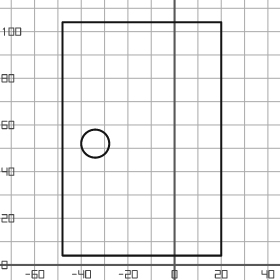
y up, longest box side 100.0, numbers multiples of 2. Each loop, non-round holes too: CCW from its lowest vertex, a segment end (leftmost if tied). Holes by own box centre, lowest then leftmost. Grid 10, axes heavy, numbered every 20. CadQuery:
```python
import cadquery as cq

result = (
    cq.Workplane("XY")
    .moveTo(-48.0, 4.0)
    .lineTo(20.0, 4.0)
    .lineTo(20.0, 104.0)
    .lineTo(-48.0, 104.0)
    .close()
    .moveTo(-34.0, 52.0)
    .circle(6.0)
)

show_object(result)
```